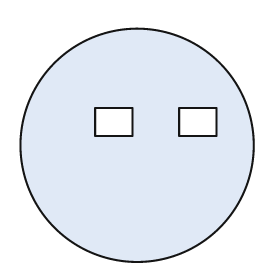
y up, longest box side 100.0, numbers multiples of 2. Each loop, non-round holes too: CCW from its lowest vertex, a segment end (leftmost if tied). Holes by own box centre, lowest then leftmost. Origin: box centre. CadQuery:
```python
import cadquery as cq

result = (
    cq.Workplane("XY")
    .moveTo(0.0, 0.0)
    .circle(50.0)
    .moveTo(-18.0, 4.0)
    .lineTo(-2.0, 4.0)
    .lineTo(-2.0, 16.0)
    .lineTo(-18.0, 16.0)
    .close()
    .moveTo(18.0, 4.0)
    .lineTo(34.0, 4.0)
    .lineTo(34.0, 16.0)
    .lineTo(18.0, 16.0)
    .close()
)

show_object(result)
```